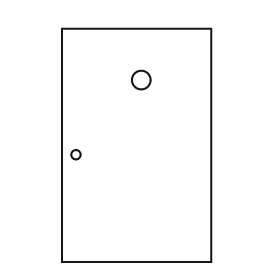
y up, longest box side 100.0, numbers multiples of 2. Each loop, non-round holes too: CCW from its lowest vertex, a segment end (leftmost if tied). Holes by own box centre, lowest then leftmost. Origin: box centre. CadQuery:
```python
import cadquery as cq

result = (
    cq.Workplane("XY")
    .moveTo(-32.0, -50.0)
    .lineTo(32.0, -50.0)
    .lineTo(32.0, 50.0)
    .lineTo(-32.0, 50.0)
    .close()
    .moveTo(-26.0, -4.0)
    .circle(2.0)
    .moveTo(2.0, 28.0)
    .circle(4.0)
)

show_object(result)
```